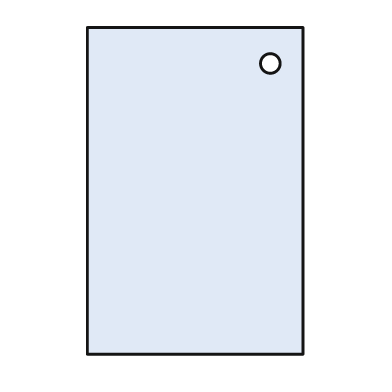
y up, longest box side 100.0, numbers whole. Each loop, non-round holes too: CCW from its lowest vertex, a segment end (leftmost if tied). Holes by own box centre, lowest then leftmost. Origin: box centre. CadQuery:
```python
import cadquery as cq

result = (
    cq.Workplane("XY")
    .moveTo(-33.0, -50.0)
    .lineTo(33.0, -50.0)
    .lineTo(33.0, 50.0)
    .lineTo(-33.0, 50.0)
    .close()
    .moveTo(23.0, 39.0)
    .circle(3.0)
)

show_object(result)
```